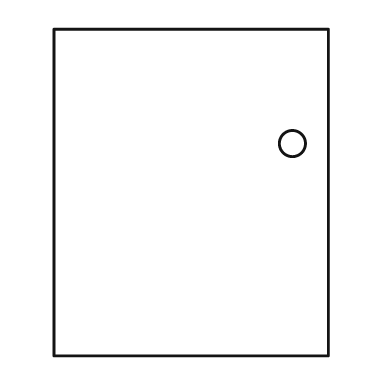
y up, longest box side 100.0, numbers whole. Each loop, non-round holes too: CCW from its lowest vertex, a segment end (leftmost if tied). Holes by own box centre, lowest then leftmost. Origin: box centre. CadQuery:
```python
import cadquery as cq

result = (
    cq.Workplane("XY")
    .moveTo(-42.0, -50.0)
    .lineTo(42.0, -50.0)
    .lineTo(42.0, 50.0)
    .lineTo(-42.0, 50.0)
    .close()
    .moveTo(31.0, 15.0)
    .circle(4.0)
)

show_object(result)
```